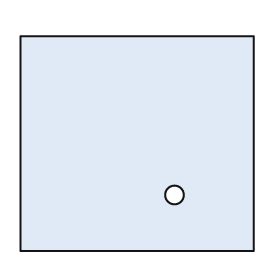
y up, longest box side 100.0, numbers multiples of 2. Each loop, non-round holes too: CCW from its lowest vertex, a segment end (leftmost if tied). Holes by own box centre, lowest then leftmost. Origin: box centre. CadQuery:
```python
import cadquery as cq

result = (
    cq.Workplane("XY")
    .moveTo(-50.0, -46.0)
    .lineTo(50.0, -46.0)
    .lineTo(50.0, 46.0)
    .lineTo(-50.0, 46.0)
    .close()
    .moveTo(16.0, -22.0)
    .circle(4.0)
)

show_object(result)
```